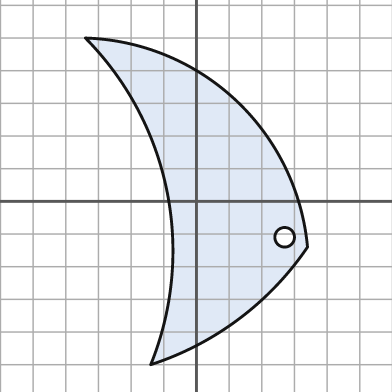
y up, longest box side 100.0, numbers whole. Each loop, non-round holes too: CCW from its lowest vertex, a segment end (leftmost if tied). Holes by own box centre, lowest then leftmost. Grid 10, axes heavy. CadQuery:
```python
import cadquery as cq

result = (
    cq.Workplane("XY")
    .moveTo(-14.0, -50.0)
    .threePointArc((13.0, -36.0), (34.0, -14.0))
    .threePointArc((12.0, 31.0), (-34.0, 50.0))
    .threePointArc((-9.0, 3.0), (-14.0, -50.0))
    .close()
    .moveTo(27.0, -11.0)
    .circle(3.0)
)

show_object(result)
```